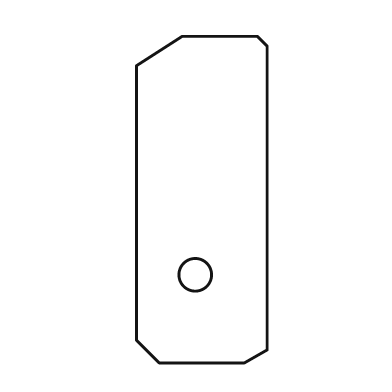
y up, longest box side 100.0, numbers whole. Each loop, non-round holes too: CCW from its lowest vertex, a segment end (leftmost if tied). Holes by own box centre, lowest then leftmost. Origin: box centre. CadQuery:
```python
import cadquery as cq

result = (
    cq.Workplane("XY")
    .moveTo(-13.0, -50.0)
    .lineTo(13.0, -50.0)
    .lineTo(20.0, -46.0)
    .lineTo(20.0, 47.0)
    .lineTo(17.0, 50.0)
    .lineTo(-6.0, 50.0)
    .lineTo(-20.0, 41.0)
    .lineTo(-20.0, -43.0)
    .close()
    .moveTo(-2.0, -23.0)
    .circle(5.0)
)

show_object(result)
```